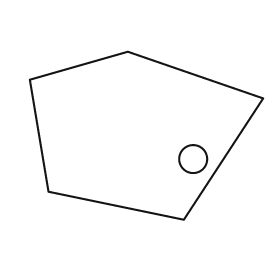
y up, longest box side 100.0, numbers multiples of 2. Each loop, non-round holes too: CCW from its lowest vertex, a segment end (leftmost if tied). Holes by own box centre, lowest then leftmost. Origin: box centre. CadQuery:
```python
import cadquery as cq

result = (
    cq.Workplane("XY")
    .moveTo(16.0, -36.0)
    .lineTo(50.0, 16.0)
    .lineTo(-8.0, 36.0)
    .lineTo(-50.0, 24.0)
    .lineTo(-42.0, -24.0)
    .close()
    .moveTo(20.0, -10.0)
    .circle(6.0)
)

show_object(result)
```